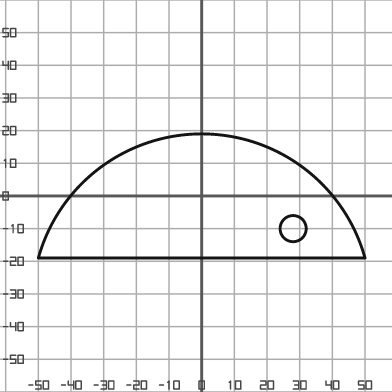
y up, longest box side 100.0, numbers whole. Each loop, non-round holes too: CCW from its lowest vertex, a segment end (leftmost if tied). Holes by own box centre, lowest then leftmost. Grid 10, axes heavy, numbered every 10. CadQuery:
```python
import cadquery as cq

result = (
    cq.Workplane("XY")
    .moveTo(-50.0, -19.0)
    .lineTo(50.0, -19.0)
    .threePointArc((0.0, 19.0), (-50.0, -19.0))
    .close()
    .moveTo(28.0, -10.0)
    .circle(4.0)
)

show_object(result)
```